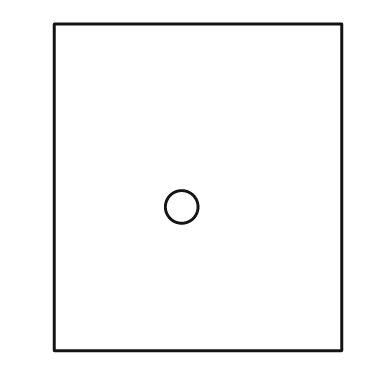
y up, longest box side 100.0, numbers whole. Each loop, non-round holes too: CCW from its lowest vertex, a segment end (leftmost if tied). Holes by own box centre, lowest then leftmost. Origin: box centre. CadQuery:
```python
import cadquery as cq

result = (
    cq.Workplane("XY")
    .moveTo(-44.0, -50.0)
    .lineTo(44.0, -50.0)
    .lineTo(44.0, 50.0)
    .lineTo(-44.0, 50.0)
    .close()
    .moveTo(-5.0, -6.0)
    .circle(5.0)
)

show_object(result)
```